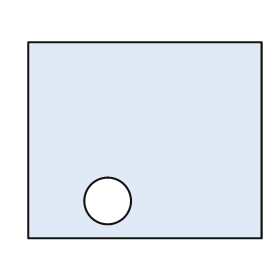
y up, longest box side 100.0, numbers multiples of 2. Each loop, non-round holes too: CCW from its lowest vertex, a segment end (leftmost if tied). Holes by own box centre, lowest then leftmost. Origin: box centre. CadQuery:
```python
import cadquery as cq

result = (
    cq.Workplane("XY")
    .moveTo(-50.0, -42.0)
    .lineTo(50.0, -42.0)
    .lineTo(50.0, 42.0)
    .lineTo(-50.0, 42.0)
    .close()
    .moveTo(-16.0, -26.0)
    .circle(10.0)
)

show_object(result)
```